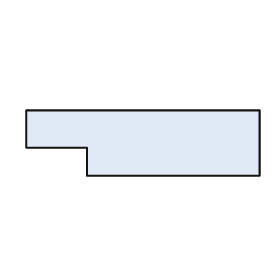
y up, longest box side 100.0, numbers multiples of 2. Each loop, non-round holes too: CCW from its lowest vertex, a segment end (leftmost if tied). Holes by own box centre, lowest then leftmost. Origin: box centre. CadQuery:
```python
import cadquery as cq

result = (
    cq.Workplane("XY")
    .moveTo(-24.0, -14.0)
    .lineTo(50.0, -14.0)
    .lineTo(50.0, 14.0)
    .lineTo(-50.0, 14.0)
    .lineTo(-50.0, -2.0)
    .lineTo(-24.0, -2.0)
    .close()
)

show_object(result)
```